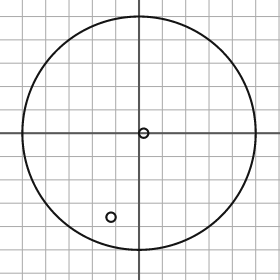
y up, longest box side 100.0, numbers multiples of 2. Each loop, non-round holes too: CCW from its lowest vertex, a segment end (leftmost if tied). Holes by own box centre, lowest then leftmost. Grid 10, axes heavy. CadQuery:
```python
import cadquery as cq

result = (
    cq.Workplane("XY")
    .moveTo(0.0, 0.0)
    .circle(50.0)
    .moveTo(-12.0, -36.0)
    .circle(2.0)
    .moveTo(2.0, 0.0)
    .circle(2.0)
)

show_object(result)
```